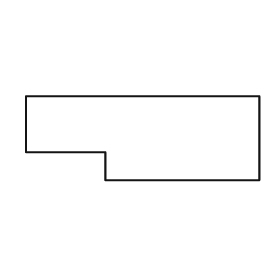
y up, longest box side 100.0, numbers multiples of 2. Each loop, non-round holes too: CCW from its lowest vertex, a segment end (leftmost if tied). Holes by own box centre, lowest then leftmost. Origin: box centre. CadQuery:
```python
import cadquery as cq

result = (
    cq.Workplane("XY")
    .moveTo(-16.0, -18.0)
    .lineTo(50.0, -18.0)
    .lineTo(50.0, 18.0)
    .lineTo(-50.0, 18.0)
    .lineTo(-50.0, -6.0)
    .lineTo(-16.0, -6.0)
    .close()
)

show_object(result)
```